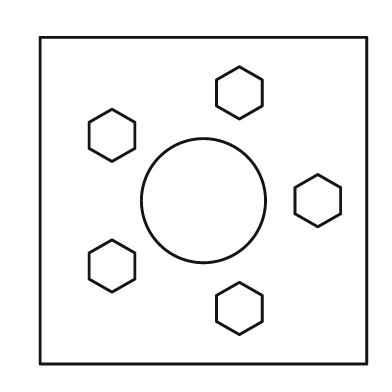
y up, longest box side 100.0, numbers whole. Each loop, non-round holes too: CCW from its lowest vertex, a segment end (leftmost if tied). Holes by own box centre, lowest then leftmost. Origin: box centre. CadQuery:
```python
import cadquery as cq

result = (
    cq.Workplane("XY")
    .moveTo(-50.0, -50.0)
    .lineTo(50.0, -50.0)
    .lineTo(50.0, 50.0)
    .lineTo(-50.0, 50.0)
    .close()
    .moveTo(11.0, -41.0)
    .lineTo(18.0, -37.0)
    .lineTo(18.0, -29.0)
    .lineTo(11.0, -25.0)
    .lineTo(4.0, -29.0)
    .lineTo(4.0, -37.0)
    .close()
    .moveTo(-28.0, -28.0)
    .lineTo(-21.0, -24.0)
    .lineTo(-21.0, -16.0)
    .lineTo(-28.0, -12.0)
    .lineTo(-35.0, -16.0)
    .lineTo(-35.0, -24.0)
    .close()
    .moveTo(0.0, 0.0)
    .circle(19.0)
    .moveTo(35.0, -8.0)
    .lineTo(42.0, -4.0)
    .lineTo(42.0, 4.0)
    .lineTo(35.0, 8.0)
    .lineTo(28.0, 4.0)
    .lineTo(28.0, -4.0)
    .close()
    .moveTo(-28.0, 12.0)
    .lineTo(-21.0, 16.0)
    .lineTo(-21.0, 24.0)
    .lineTo(-28.0, 28.0)
    .lineTo(-35.0, 24.0)
    .lineTo(-35.0, 16.0)
    .close()
    .moveTo(11.0, 25.0)
    .lineTo(18.0, 29.0)
    .lineTo(18.0, 37.0)
    .lineTo(11.0, 41.0)
    .lineTo(4.0, 37.0)
    .lineTo(4.0, 29.0)
    .close()
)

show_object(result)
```